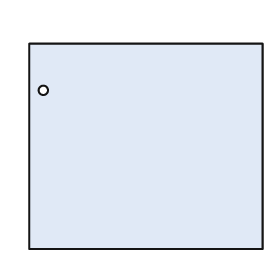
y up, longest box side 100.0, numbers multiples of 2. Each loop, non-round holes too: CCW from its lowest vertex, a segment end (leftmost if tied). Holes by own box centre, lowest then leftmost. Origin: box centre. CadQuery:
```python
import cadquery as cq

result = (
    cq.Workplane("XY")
    .moveTo(-50.0, -44.0)
    .lineTo(50.0, -44.0)
    .lineTo(50.0, 44.0)
    .lineTo(-50.0, 44.0)
    .close()
    .moveTo(-44.0, 24.0)
    .circle(2.0)
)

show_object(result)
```